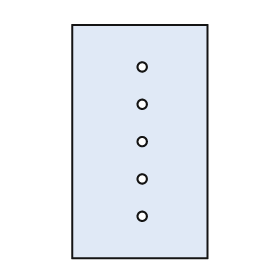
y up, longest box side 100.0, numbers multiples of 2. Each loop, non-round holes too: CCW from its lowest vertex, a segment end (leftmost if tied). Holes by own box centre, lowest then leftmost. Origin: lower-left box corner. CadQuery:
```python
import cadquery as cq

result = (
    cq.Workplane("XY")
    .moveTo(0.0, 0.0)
    .lineTo(58.0, 0.0)
    .lineTo(58.0, 100.0)
    .lineTo(0.0, 100.0)
    .close()
    .moveTo(30.0, 18.0)
    .circle(2.0)
    .moveTo(30.0, 34.0)
    .circle(2.0)
    .moveTo(30.0, 50.0)
    .circle(2.0)
    .moveTo(30.0, 66.0)
    .circle(2.0)
    .moveTo(30.0, 82.0)
    .circle(2.0)
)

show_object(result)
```